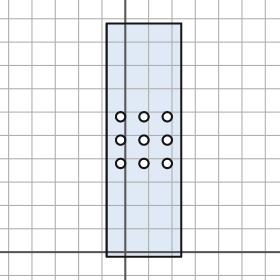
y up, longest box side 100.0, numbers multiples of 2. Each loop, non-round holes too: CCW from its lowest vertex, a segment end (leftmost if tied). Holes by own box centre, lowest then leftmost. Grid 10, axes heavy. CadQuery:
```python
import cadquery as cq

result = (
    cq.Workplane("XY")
    .moveTo(-8.0, -2.0)
    .lineTo(24.0, -2.0)
    .lineTo(24.0, 98.0)
    .lineTo(-8.0, 98.0)
    .close()
    .moveTo(-2.0, 38.0)
    .circle(2.0)
    .moveTo(8.0, 38.0)
    .circle(2.0)
    .moveTo(18.0, 38.0)
    .circle(2.0)
    .moveTo(-2.0, 48.0)
    .circle(2.0)
    .moveTo(8.0, 48.0)
    .circle(2.0)
    .moveTo(18.0, 48.0)
    .circle(2.0)
    .moveTo(-2.0, 58.0)
    .circle(2.0)
    .moveTo(8.0, 58.0)
    .circle(2.0)
    .moveTo(18.0, 58.0)
    .circle(2.0)
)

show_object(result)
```